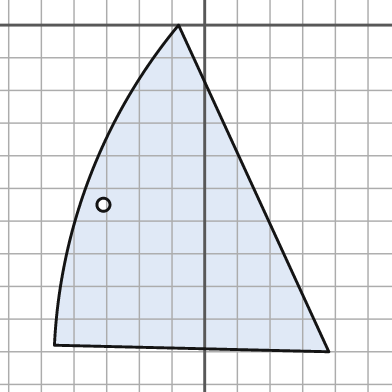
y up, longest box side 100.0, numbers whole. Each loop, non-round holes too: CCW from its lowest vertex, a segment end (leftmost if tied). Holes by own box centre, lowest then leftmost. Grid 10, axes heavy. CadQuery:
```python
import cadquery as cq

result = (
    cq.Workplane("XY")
    .moveTo(38.0, -100.0)
    .lineTo(-8.0, 0.0)
    .threePointArc((-35.0, -46.0), (-46.0, -98.0))
    .close()
    .moveTo(-31.0, -55.0)
    .circle(2.0)
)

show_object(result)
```